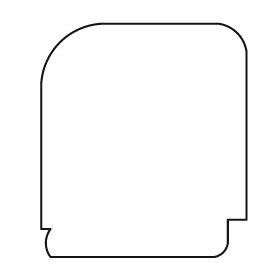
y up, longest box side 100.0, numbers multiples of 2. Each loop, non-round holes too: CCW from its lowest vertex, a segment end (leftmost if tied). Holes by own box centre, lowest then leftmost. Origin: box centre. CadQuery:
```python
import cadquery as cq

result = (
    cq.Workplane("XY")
    .moveTo(-40.0, -50.0)
    .lineTo(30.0, -50.0)
    .threePointArc((34.0, -48.0), (36.0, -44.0))
    .lineTo(36.0, -34.0)
    .lineTo(44.0, -34.0)
    .lineTo(44.0, 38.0)
    .threePointArc((40.0, 46.0), (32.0, 50.0))
    .lineTo(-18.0, 50.0)
    .threePointArc((-36.0, 42.0), (-44.0, 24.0))
    .lineTo(-44.0, -38.0)
    .lineTo(-40.0, -38.0)
    .threePointArc((-42.0, -44.0), (-40.0, -50.0))
    .close()
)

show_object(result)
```